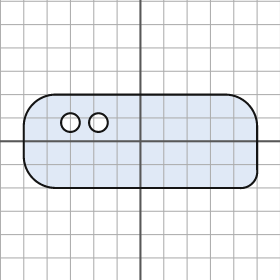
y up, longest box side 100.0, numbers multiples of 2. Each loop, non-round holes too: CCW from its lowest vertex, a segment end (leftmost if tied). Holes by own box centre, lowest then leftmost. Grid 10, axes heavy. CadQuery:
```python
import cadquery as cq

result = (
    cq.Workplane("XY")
    .moveTo(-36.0, -20.0)
    .lineTo(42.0, -20.0)
    .threePointArc((48.0, -18.0), (50.0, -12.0))
    .lineTo(50.0, 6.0)
    .threePointArc((46.0, 16.0), (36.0, 20.0))
    .lineTo(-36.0, 20.0)
    .threePointArc((-46.0, 16.0), (-50.0, 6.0))
    .lineTo(-50.0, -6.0)
    .threePointArc((-46.0, -16.0), (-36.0, -20.0))
    .close()
    .moveTo(-30.0, 8.0)
    .circle(4.0)
    .moveTo(-18.0, 8.0)
    .circle(4.0)
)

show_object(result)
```